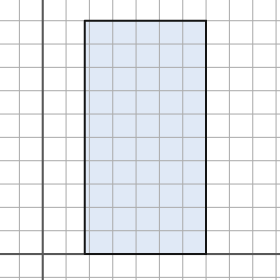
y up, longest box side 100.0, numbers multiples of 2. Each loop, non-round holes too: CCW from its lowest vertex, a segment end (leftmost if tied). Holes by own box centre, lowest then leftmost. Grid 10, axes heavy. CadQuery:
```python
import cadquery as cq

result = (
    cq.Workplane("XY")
    .moveTo(18.0, 0.0)
    .lineTo(70.0, 0.0)
    .lineTo(70.0, 100.0)
    .lineTo(18.0, 100.0)
    .close()
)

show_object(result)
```